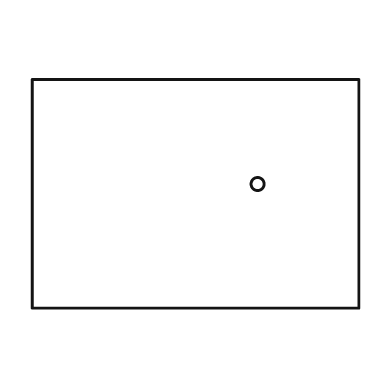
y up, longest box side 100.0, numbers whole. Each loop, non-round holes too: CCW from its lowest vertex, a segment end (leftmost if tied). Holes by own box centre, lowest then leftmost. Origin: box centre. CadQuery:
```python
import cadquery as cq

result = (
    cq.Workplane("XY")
    .moveTo(-50.0, -35.0)
    .lineTo(50.0, -35.0)
    .lineTo(50.0, 35.0)
    .lineTo(-50.0, 35.0)
    .close()
    .moveTo(19.0, 3.0)
    .circle(2.0)
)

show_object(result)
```